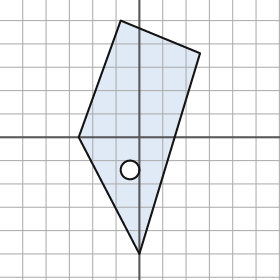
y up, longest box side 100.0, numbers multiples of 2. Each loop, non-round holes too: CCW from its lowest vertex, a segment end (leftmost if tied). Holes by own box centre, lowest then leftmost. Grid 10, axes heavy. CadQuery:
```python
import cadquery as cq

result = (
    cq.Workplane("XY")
    .moveTo(0.0, -50.0)
    .lineTo(26.0, 36.0)
    .lineTo(-8.0, 50.0)
    .lineTo(-26.0, 0.0)
    .close()
    .moveTo(-4.0, -14.0)
    .circle(4.0)
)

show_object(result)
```